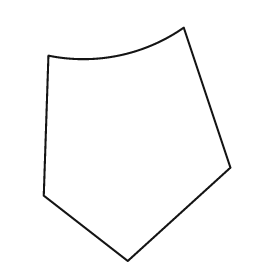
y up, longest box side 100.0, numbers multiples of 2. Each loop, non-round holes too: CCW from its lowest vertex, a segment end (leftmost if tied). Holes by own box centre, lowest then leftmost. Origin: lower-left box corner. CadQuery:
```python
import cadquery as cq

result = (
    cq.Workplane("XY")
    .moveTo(36.0, 0.0)
    .lineTo(80.0, 40.0)
    .lineTo(60.0, 100.0)
    .threePointArc((32.0, 88.0), (2.0, 88.0))
    .lineTo(0.0, 28.0)
    .close()
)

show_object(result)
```